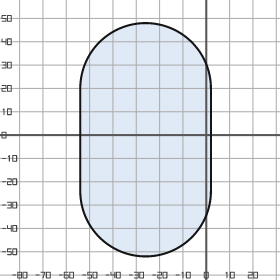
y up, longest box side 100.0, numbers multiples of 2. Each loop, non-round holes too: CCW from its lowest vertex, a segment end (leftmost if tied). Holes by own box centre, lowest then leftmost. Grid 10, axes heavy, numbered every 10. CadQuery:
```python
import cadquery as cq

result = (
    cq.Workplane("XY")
    .moveTo(-54.0, -24.0)
    .threePointArc((-26.0, -52.0), (2.0, -24.0))
    .lineTo(2.0, 20.0)
    .threePointArc((-26.0, 48.0), (-54.0, 20.0))
    .close()
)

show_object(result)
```